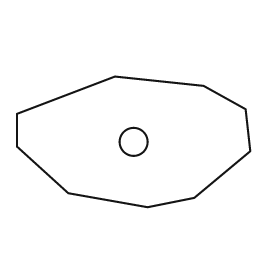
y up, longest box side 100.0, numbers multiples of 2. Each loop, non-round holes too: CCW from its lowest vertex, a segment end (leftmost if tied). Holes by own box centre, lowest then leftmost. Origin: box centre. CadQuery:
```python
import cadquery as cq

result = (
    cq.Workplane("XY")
    .moveTo(6.0, -28.0)
    .lineTo(26.0, -24.0)
    .lineTo(50.0, -4.0)
    .lineTo(48.0, 14.0)
    .lineTo(30.0, 24.0)
    .lineTo(-8.0, 28.0)
    .lineTo(-50.0, 12.0)
    .lineTo(-50.0, -2.0)
    .lineTo(-28.0, -22.0)
    .close()
    .moveTo(0.0, 0.0)
    .circle(6.0)
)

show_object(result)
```